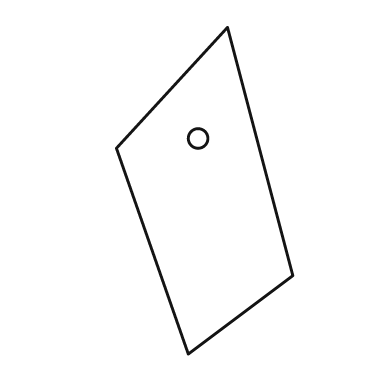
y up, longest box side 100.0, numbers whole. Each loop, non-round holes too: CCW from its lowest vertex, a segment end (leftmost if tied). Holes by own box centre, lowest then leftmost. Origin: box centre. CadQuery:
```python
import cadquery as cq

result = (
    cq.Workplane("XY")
    .moveTo(-5.0, -50.0)
    .lineTo(27.0, -26.0)
    .lineTo(7.0, 50.0)
    .lineTo(-27.0, 13.0)
    .close()
    .moveTo(-2.0, 16.0)
    .circle(3.0)
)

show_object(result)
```